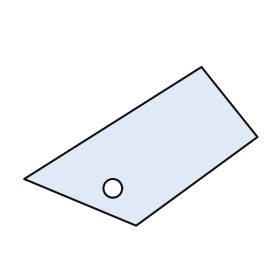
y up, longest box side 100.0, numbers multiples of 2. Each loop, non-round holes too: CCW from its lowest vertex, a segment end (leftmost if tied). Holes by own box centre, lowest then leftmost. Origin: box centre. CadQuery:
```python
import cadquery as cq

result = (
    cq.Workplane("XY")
    .moveTo(-2.0, -34.0)
    .lineTo(50.0, 4.0)
    .lineTo(26.0, 34.0)
    .lineTo(-50.0, -14.0)
    .close()
    .moveTo(-12.0, -18.0)
    .circle(4.0)
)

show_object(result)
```